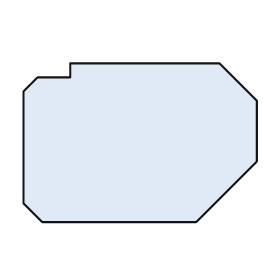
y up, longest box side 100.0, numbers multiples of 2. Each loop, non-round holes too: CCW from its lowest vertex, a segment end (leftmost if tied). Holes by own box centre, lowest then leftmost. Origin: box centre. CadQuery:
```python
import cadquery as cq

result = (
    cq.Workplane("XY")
    .moveTo(-42.0, -34.0)
    .lineTo(24.0, -34.0)
    .lineTo(50.0, -8.0)
    .lineTo(50.0, 18.0)
    .lineTo(34.0, 34.0)
    .lineTo(-30.0, 34.0)
    .lineTo(-30.0, 28.0)
    .lineTo(-44.0, 28.0)
    .lineTo(-50.0, 22.0)
    .lineTo(-50.0, -26.0)
    .close()
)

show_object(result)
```